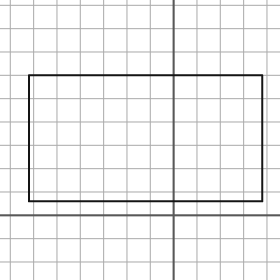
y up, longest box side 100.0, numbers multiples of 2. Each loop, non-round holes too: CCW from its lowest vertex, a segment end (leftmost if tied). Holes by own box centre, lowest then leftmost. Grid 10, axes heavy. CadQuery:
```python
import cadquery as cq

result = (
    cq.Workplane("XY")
    .moveTo(-62.0, 6.0)
    .lineTo(38.0, 6.0)
    .lineTo(38.0, 60.0)
    .lineTo(-62.0, 60.0)
    .close()
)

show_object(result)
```